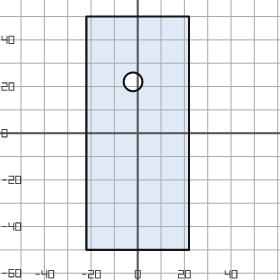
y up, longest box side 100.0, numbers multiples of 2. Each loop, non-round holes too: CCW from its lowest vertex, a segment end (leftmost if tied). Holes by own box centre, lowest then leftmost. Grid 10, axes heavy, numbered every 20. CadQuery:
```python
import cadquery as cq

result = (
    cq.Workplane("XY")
    .moveTo(-22.0, -50.0)
    .lineTo(22.0, -50.0)
    .lineTo(22.0, 50.0)
    .lineTo(-22.0, 50.0)
    .close()
    .moveTo(-2.0, 22.0)
    .circle(4.0)
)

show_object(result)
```